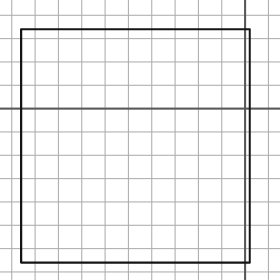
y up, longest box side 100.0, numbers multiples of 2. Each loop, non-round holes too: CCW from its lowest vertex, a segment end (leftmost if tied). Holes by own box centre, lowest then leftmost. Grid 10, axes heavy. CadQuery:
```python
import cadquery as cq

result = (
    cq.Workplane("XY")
    .moveTo(-96.0, -66.0)
    .lineTo(2.0, -66.0)
    .lineTo(2.0, 34.0)
    .lineTo(-96.0, 34.0)
    .close()
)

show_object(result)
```